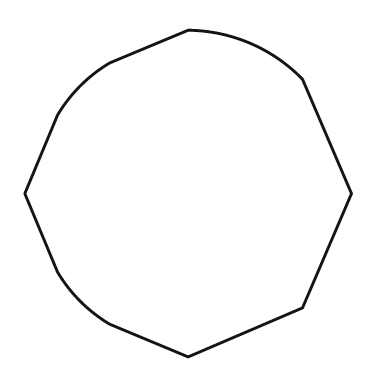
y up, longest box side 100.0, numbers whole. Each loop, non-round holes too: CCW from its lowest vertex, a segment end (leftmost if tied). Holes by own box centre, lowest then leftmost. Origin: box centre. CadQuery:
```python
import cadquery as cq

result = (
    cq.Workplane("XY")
    .moveTo(0.0, -50.0)
    .lineTo(35.0, -35.0)
    .lineTo(50.0, 0.0)
    .lineTo(35.0, 35.0)
    .threePointArc((19.0, 46.0), (0.0, 50.0))
    .lineTo(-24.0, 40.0)
    .threePointArc((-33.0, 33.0), (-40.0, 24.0))
    .lineTo(-50.0, 0.0)
    .lineTo(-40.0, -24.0)
    .threePointArc((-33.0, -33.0), (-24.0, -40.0))
    .close()
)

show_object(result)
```